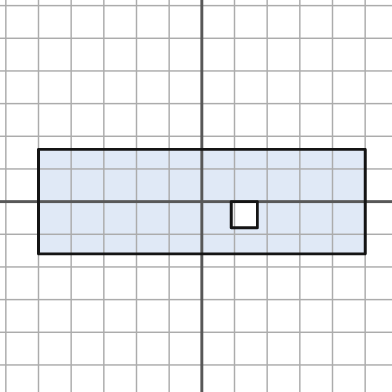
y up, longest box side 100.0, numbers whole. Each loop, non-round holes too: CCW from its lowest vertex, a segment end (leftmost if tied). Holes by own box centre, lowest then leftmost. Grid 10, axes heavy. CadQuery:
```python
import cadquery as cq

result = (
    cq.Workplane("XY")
    .moveTo(-50.0, -16.0)
    .lineTo(50.0, -16.0)
    .lineTo(50.0, 16.0)
    .lineTo(-50.0, 16.0)
    .close()
    .moveTo(9.0, -8.0)
    .lineTo(17.0, -8.0)
    .lineTo(17.0, 0.0)
    .lineTo(9.0, 0.0)
    .close()
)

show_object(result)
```